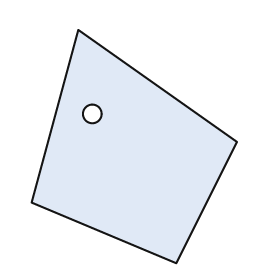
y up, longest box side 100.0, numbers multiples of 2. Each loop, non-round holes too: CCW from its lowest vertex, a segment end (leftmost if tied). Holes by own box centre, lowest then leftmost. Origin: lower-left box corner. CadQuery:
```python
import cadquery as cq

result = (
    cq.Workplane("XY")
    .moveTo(62.0, 0.0)
    .lineTo(88.0, 52.0)
    .lineTo(20.0, 100.0)
    .lineTo(0.0, 26.0)
    .close()
    .moveTo(26.0, 64.0)
    .circle(4.0)
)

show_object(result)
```